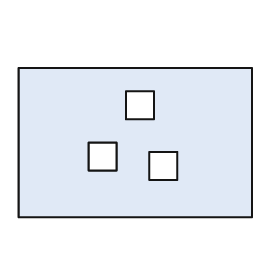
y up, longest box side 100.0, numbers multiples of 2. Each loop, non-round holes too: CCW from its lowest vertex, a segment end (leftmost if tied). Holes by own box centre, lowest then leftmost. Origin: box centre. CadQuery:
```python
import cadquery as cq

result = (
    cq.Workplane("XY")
    .moveTo(-50.0, -32.0)
    .lineTo(50.0, -32.0)
    .lineTo(50.0, 32.0)
    .lineTo(-50.0, 32.0)
    .close()
    .moveTo(6.0, -16.0)
    .lineTo(18.0, -16.0)
    .lineTo(18.0, -4.0)
    .lineTo(6.0, -4.0)
    .close()
    .moveTo(-20.0, -12.0)
    .lineTo(-8.0, -12.0)
    .lineTo(-8.0, 0.0)
    .lineTo(-20.0, 0.0)
    .close()
    .moveTo(-4.0, 10.0)
    .lineTo(8.0, 10.0)
    .lineTo(8.0, 22.0)
    .lineTo(-4.0, 22.0)
    .close()
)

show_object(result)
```